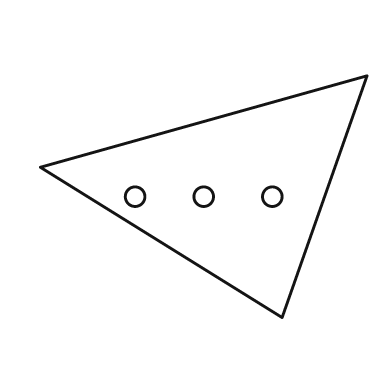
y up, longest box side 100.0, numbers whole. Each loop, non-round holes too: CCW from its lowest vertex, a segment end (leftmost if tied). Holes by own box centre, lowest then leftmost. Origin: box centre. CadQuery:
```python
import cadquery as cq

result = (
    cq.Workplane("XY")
    .moveTo(24.0, -37.0)
    .lineTo(50.0, 37.0)
    .lineTo(-50.0, 9.0)
    .close()
    .moveTo(-21.0, 0.0)
    .circle(3.0)
    .moveTo(0.0, 0.0)
    .circle(3.0)
    .moveTo(21.0, 0.0)
    .circle(3.0)
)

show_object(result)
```